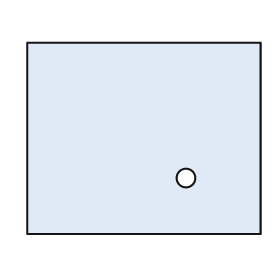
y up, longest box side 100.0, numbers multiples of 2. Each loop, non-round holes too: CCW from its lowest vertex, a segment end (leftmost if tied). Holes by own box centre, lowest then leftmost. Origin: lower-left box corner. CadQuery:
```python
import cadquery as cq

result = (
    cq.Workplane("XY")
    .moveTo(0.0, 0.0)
    .lineTo(100.0, 0.0)
    .lineTo(100.0, 82.0)
    .lineTo(0.0, 82.0)
    .close()
    .moveTo(68.0, 24.0)
    .circle(4.0)
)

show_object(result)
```